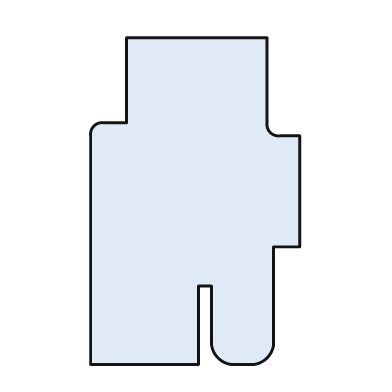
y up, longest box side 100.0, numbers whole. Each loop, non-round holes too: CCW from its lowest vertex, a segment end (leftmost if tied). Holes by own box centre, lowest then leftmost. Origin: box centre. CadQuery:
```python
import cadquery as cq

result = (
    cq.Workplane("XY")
    .moveTo(-32.0, -50.0)
    .lineTo(1.0, -50.0)
    .lineTo(1.0, -26.0)
    .lineTo(5.0, -26.0)
    .lineTo(5.0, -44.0)
    .threePointArc((7.0, -48.0), (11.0, -50.0))
    .lineTo(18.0, -50.0)
    .threePointArc((22.0, -48.0), (24.0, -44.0))
    .lineTo(24.0, -14.0)
    .lineTo(32.0, -14.0)
    .lineTo(32.0, 20.0)
    .lineTo(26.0, 20.0)
    .threePointArc((23.0, 21.0), (22.0, 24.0))
    .lineTo(22.0, 50.0)
    .lineTo(-21.0, 50.0)
    .lineTo(-21.0, 24.0)
    .lineTo(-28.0, 24.0)
    .threePointArc((-31.0, 23.0), (-32.0, 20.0))
    .close()
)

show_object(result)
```